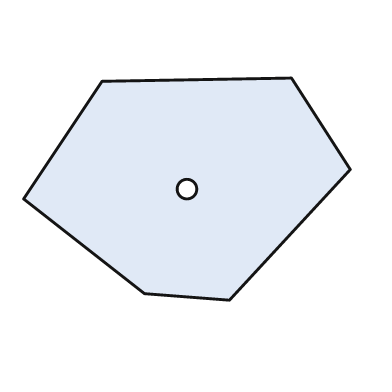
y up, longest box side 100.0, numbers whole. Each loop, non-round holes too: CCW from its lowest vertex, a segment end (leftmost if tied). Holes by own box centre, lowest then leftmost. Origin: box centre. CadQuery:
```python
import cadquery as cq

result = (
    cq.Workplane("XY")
    .moveTo(13.0, -34.0)
    .lineTo(50.0, 6.0)
    .lineTo(32.0, 34.0)
    .lineTo(-26.0, 33.0)
    .lineTo(-50.0, -3.0)
    .lineTo(-13.0, -32.0)
    .close()
    .moveTo(0.0, 0.0)
    .circle(3.0)
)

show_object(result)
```